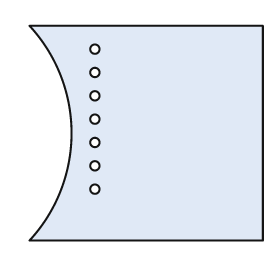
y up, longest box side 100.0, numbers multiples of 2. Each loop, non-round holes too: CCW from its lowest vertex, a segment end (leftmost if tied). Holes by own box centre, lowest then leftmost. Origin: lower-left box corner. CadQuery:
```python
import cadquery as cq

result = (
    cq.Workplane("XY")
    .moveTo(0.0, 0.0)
    .lineTo(100.0, 0.0)
    .lineTo(100.0, 92.0)
    .lineTo(0.0, 92.0)
    .threePointArc((18.0, 46.0), (0.0, 0.0))
    .close()
    .moveTo(28.0, 22.0)
    .circle(2.0)
    .moveTo(28.0, 32.0)
    .circle(2.0)
    .moveTo(28.0, 42.0)
    .circle(2.0)
    .moveTo(28.0, 52.0)
    .circle(2.0)
    .moveTo(28.0, 62.0)
    .circle(2.0)
    .moveTo(28.0, 72.0)
    .circle(2.0)
    .moveTo(28.0, 82.0)
    .circle(2.0)
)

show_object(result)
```